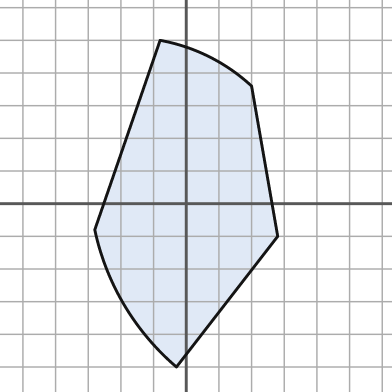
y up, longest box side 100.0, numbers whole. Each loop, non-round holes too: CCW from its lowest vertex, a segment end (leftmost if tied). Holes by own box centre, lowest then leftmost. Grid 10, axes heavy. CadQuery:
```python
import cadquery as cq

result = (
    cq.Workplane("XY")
    .moveTo(-3.0, -50.0)
    .lineTo(28.0, -10.0)
    .lineTo(20.0, 36.0)
    .threePointArc((7.0, 45.0), (-8.0, 50.0))
    .lineTo(-28.0, -8.0)
    .threePointArc((-19.0, -31.0), (-3.0, -50.0))
    .close()
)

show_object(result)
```